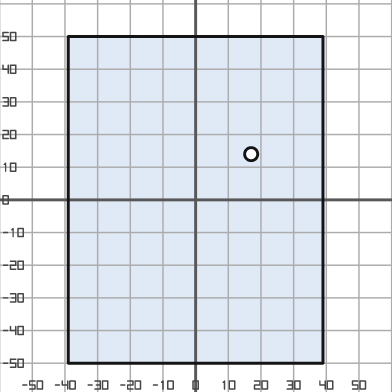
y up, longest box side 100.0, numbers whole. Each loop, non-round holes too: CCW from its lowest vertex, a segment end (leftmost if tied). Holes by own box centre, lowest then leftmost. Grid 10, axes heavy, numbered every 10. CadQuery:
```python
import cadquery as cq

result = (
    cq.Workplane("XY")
    .moveTo(-39.0, -50.0)
    .lineTo(39.0, -50.0)
    .lineTo(39.0, 50.0)
    .lineTo(-39.0, 50.0)
    .close()
    .moveTo(17.0, 14.0)
    .circle(2.0)
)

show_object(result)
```